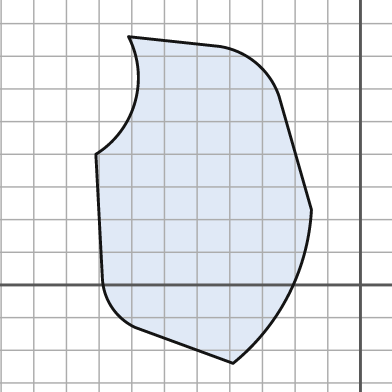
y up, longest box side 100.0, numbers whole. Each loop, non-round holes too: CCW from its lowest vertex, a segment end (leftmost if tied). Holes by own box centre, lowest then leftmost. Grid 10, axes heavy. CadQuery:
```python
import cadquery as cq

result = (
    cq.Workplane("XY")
    .moveTo(-39.0, -24.0)
    .threePointArc((-22.0, -3.0), (-15.0, 23.0))
    .lineTo(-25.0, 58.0)
    .threePointArc((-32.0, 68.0), (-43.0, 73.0))
    .lineTo(-71.0, 76.0)
    .threePointArc((-69.0, 56.0), (-81.0, 40.0))
    .lineTo(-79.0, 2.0)
    .threePointArc((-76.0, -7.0), (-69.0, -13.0))
    .close()
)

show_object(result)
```